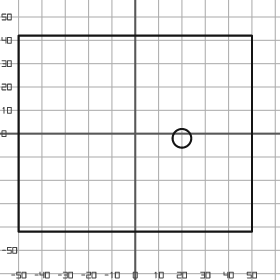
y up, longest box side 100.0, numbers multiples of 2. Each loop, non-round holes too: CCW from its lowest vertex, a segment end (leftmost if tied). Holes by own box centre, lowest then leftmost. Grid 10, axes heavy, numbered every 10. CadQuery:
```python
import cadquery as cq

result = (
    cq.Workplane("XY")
    .moveTo(-50.0, -42.0)
    .lineTo(50.0, -42.0)
    .lineTo(50.0, 42.0)
    .lineTo(-50.0, 42.0)
    .close()
    .moveTo(20.0, -2.0)
    .circle(4.0)
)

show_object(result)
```